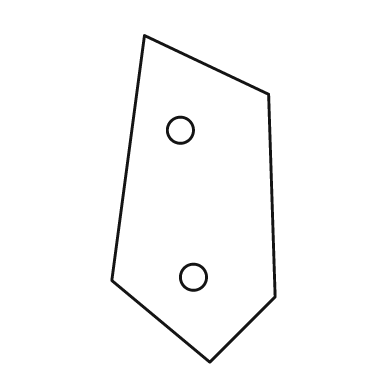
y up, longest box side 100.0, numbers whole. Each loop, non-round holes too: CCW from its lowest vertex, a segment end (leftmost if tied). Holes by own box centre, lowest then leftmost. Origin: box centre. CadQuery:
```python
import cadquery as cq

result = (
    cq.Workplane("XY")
    .moveTo(5.0, -50.0)
    .lineTo(25.0, -30.0)
    .lineTo(23.0, 32.0)
    .lineTo(-15.0, 50.0)
    .lineTo(-25.0, -25.0)
    .close()
    .moveTo(0.0, -24.0)
    .circle(4.0)
    .moveTo(-4.0, 21.0)
    .circle(4.0)
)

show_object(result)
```